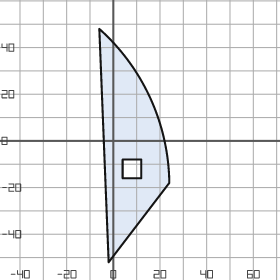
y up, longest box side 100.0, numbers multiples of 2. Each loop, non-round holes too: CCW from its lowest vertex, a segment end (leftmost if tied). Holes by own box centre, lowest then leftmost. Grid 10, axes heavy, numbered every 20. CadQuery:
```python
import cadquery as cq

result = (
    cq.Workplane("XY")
    .moveTo(-2.0, -52.0)
    .lineTo(24.0, -18.0)
    .threePointArc((16.0, 18.0), (-6.0, 48.0))
    .close()
    .moveTo(4.0, -16.0)
    .lineTo(12.0, -16.0)
    .lineTo(12.0, -8.0)
    .lineTo(4.0, -8.0)
    .close()
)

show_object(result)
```